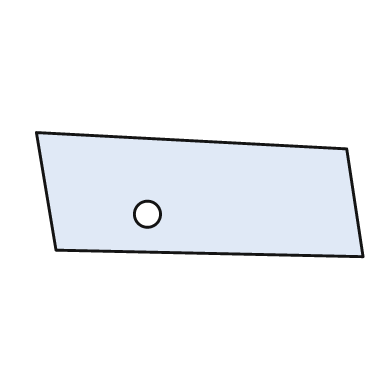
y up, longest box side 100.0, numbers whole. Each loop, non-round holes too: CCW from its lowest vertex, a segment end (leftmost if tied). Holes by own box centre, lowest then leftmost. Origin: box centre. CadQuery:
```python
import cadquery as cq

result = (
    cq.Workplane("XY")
    .moveTo(50.0, -19.0)
    .lineTo(45.0, 14.0)
    .lineTo(-50.0, 19.0)
    .lineTo(-44.0, -17.0)
    .close()
    .moveTo(-16.0, -6.0)
    .circle(4.0)
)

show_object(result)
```